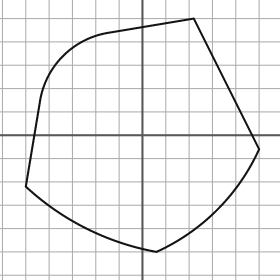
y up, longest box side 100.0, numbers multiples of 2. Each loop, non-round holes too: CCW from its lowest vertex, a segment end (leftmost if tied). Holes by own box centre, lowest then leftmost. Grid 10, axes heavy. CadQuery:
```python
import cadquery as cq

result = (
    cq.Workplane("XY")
    .moveTo(6.0, -50.0)
    .threePointArc((32.0, -32.0), (50.0, -6.0))
    .lineTo(22.0, 50.0)
    .lineTo(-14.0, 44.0)
    .threePointArc((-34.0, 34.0), (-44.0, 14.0))
    .lineTo(-50.0, -22.0)
    .threePointArc((-24.0, -40.0), (6.0, -50.0))
    .close()
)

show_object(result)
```